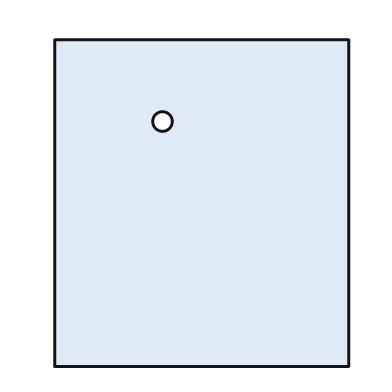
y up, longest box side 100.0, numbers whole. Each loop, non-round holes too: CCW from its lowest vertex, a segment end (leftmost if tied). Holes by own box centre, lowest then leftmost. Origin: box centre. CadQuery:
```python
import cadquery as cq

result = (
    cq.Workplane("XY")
    .moveTo(-45.0, -50.0)
    .lineTo(45.0, -50.0)
    .lineTo(45.0, 50.0)
    .lineTo(-45.0, 50.0)
    .close()
    .moveTo(-12.0, 25.0)
    .circle(3.0)
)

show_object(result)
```